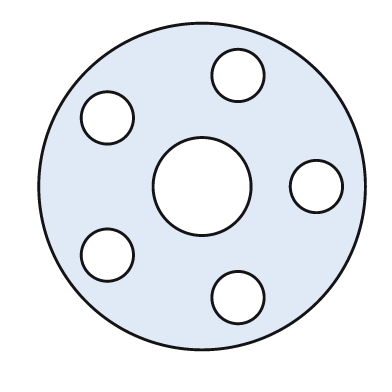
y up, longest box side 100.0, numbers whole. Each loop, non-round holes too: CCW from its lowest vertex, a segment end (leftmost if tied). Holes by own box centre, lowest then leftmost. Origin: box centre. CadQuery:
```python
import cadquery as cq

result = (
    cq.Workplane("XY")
    .moveTo(0.0, 0.0)
    .circle(50.0)
    .moveTo(11.0, -34.0)
    .circle(8.0)
    .moveTo(-29.0, -21.0)
    .circle(8.0)
    .moveTo(0.0, 0.0)
    .circle(15.0)
    .moveTo(35.0, 0.0)
    .circle(8.0)
    .moveTo(-29.0, 21.0)
    .circle(8.0)
    .moveTo(11.0, 34.0)
    .circle(8.0)
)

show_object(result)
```